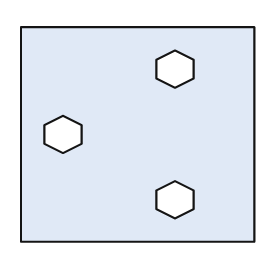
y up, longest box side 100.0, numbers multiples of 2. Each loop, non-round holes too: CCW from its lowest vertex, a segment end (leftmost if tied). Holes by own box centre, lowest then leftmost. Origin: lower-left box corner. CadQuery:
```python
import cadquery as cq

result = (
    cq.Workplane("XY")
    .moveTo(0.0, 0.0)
    .lineTo(100.0, 0.0)
    .lineTo(100.0, 92.0)
    .lineTo(0.0, 92.0)
    .close()
    .moveTo(66.0, 10.0)
    .lineTo(74.0, 14.0)
    .lineTo(74.0, 22.0)
    .lineTo(66.0, 26.0)
    .lineTo(58.0, 22.0)
    .lineTo(58.0, 14.0)
    .close()
    .moveTo(18.0, 38.0)
    .lineTo(26.0, 42.0)
    .lineTo(26.0, 50.0)
    .lineTo(18.0, 54.0)
    .lineTo(10.0, 50.0)
    .lineTo(10.0, 42.0)
    .close()
    .moveTo(66.0, 66.0)
    .lineTo(74.0, 70.0)
    .lineTo(74.0, 78.0)
    .lineTo(66.0, 82.0)
    .lineTo(58.0, 78.0)
    .lineTo(58.0, 70.0)
    .close()
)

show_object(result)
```